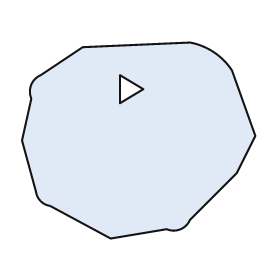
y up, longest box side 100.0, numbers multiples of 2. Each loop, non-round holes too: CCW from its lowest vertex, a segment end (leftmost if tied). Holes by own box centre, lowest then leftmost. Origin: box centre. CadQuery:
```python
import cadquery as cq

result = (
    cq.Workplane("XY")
    .moveTo(-12.0, -42.0)
    .lineTo(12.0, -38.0)
    .threePointArc((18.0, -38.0), (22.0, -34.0))
    .lineTo(42.0, -14.0)
    .lineTo(50.0, 2.0)
    .lineTo(40.0, 30.0)
    .threePointArc((32.0, 38.0), (22.0, 42.0))
    .lineTo(-24.0, 40.0)
    .lineTo(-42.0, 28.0)
    .threePointArc((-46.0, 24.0), (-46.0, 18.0))
    .lineTo(-50.0, 0.0)
    .lineTo(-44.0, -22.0)
    .threePointArc((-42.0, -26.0), (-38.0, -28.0))
    .close()
    .moveTo(-8.0, 16.0)
    .lineTo(2.0, 22.0)
    .lineTo(-8.0, 28.0)
    .close()
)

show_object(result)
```